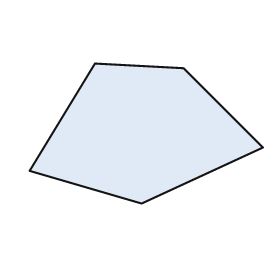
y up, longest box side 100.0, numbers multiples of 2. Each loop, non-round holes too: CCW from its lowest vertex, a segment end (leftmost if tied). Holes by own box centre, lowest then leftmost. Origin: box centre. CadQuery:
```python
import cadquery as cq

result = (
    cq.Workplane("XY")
    .moveTo(-2.0, -30.0)
    .lineTo(50.0, -6.0)
    .lineTo(16.0, 28.0)
    .lineTo(-22.0, 30.0)
    .lineTo(-50.0, -16.0)
    .close()
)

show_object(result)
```